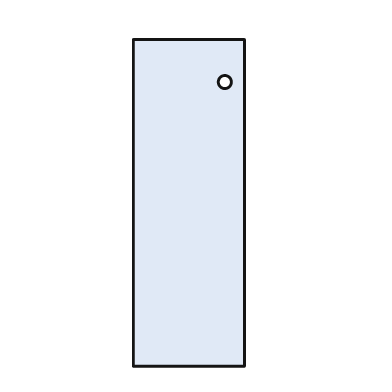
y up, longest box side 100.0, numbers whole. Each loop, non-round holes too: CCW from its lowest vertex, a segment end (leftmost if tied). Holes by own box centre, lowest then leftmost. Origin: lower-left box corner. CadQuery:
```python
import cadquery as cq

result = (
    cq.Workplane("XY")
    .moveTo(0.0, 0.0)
    .lineTo(34.0, 0.0)
    .lineTo(34.0, 100.0)
    .lineTo(0.0, 100.0)
    .close()
    .moveTo(28.0, 87.0)
    .circle(2.0)
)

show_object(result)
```